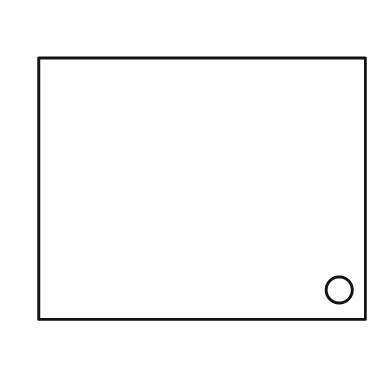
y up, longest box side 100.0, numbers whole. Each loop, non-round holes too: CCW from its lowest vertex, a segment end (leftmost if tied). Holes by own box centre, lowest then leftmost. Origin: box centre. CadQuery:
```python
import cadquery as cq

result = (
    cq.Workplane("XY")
    .moveTo(-50.0, -40.0)
    .lineTo(50.0, -40.0)
    .lineTo(50.0, 40.0)
    .lineTo(-50.0, 40.0)
    .close()
    .moveTo(42.0, -31.0)
    .circle(4.0)
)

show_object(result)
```